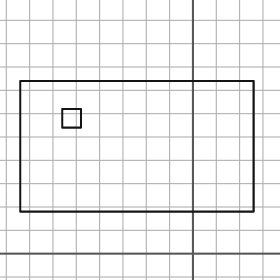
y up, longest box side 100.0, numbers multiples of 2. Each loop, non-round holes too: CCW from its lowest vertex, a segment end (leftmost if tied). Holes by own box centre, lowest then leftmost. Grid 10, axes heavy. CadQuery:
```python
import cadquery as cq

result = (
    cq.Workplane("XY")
    .moveTo(-74.0, 18.0)
    .lineTo(26.0, 18.0)
    .lineTo(26.0, 74.0)
    .lineTo(-74.0, 74.0)
    .close()
    .moveTo(-56.0, 54.0)
    .lineTo(-48.0, 54.0)
    .lineTo(-48.0, 62.0)
    .lineTo(-56.0, 62.0)
    .close()
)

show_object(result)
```